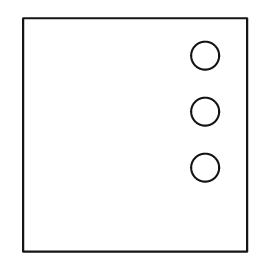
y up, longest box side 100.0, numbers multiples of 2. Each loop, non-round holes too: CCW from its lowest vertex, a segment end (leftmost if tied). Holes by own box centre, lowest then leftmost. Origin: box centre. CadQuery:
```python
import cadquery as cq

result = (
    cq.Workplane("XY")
    .moveTo(-48.0, -50.0)
    .lineTo(48.0, -50.0)
    .lineTo(48.0, 50.0)
    .lineTo(-48.0, 50.0)
    .close()
    .moveTo(30.0, -14.0)
    .circle(6.0)
    .moveTo(30.0, 10.0)
    .circle(6.0)
    .moveTo(30.0, 34.0)
    .circle(6.0)
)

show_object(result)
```